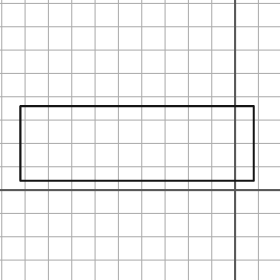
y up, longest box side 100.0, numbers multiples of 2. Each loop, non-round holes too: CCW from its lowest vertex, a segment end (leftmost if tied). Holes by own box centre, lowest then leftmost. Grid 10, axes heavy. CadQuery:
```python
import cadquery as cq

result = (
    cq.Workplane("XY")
    .moveTo(-92.0, 4.0)
    .lineTo(8.0, 4.0)
    .lineTo(8.0, 36.0)
    .lineTo(-92.0, 36.0)
    .close()
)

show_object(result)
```